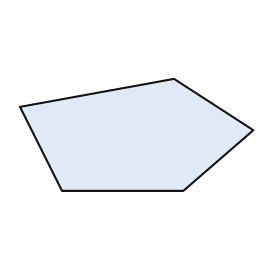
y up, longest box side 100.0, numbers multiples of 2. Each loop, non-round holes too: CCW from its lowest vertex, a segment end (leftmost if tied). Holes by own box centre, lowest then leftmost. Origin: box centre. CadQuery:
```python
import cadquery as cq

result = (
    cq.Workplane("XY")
    .moveTo(-32.0, -24.0)
    .lineTo(20.0, -24.0)
    .lineTo(50.0, 2.0)
    .lineTo(16.0, 24.0)
    .lineTo(-50.0, 12.0)
    .close()
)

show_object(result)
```